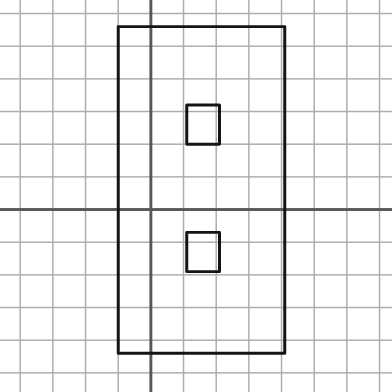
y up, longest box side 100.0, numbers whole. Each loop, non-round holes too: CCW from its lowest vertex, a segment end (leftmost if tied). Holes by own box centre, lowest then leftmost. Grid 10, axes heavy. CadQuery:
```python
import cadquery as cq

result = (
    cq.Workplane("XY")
    .moveTo(-10.0, -44.0)
    .lineTo(41.0, -44.0)
    .lineTo(41.0, 56.0)
    .lineTo(-10.0, 56.0)
    .close()
    .moveTo(11.0, -19.0)
    .lineTo(21.0, -19.0)
    .lineTo(21.0, -7.0)
    .lineTo(11.0, -7.0)
    .close()
    .moveTo(11.0, 20.0)
    .lineTo(21.0, 20.0)
    .lineTo(21.0, 32.0)
    .lineTo(11.0, 32.0)
    .close()
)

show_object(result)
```